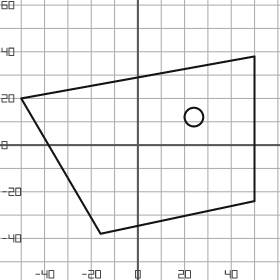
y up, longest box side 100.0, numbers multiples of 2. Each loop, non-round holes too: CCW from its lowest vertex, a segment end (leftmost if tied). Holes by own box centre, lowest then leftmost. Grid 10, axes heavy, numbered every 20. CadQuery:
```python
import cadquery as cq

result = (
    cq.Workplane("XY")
    .moveTo(-16.0, -38.0)
    .lineTo(50.0, -24.0)
    .lineTo(50.0, 38.0)
    .lineTo(-50.0, 20.0)
    .close()
    .moveTo(24.0, 12.0)
    .circle(4.0)
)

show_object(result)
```